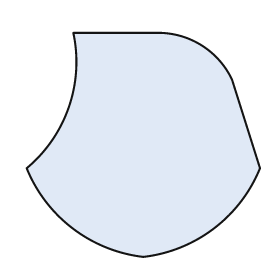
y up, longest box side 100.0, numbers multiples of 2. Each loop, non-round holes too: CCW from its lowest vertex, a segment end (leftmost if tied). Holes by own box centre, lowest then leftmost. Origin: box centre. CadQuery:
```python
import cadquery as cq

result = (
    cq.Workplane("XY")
    .moveTo(0.0, -48.0)
    .threePointArc((30.0, -36.0), (50.0, -10.0))
    .lineTo(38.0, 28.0)
    .threePointArc((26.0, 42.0), (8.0, 48.0))
    .lineTo(-30.0, 48.0)
    .threePointArc((-32.0, 16.0), (-50.0, -10.0))
    .threePointArc((-30.0, -36.0), (0.0, -48.0))
    .close()
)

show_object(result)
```